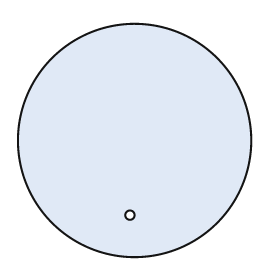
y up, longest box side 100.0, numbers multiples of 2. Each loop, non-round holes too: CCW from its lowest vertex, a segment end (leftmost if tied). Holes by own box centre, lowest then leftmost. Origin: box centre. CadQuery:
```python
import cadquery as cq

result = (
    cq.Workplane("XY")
    .moveTo(0.0, 0.0)
    .circle(50.0)
    .moveTo(-2.0, -32.0)
    .circle(2.0)
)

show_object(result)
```